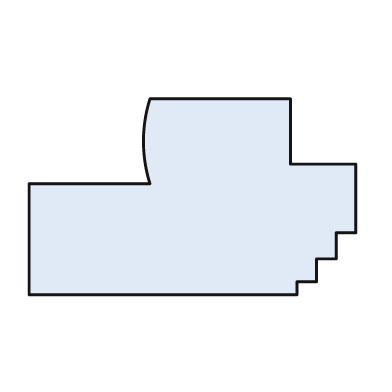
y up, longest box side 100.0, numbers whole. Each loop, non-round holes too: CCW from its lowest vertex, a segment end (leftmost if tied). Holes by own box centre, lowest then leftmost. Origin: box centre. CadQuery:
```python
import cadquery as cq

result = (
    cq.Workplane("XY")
    .moveTo(-50.0, -30.0)
    .lineTo(32.0, -30.0)
    .lineTo(32.0, -26.0)
    .lineTo(38.0, -26.0)
    .lineTo(38.0, -19.0)
    .lineTo(44.0, -19.0)
    .lineTo(44.0, -11.0)
    .lineTo(50.0, -11.0)
    .lineTo(50.0, 10.0)
    .lineTo(30.0, 10.0)
    .lineTo(30.0, 30.0)
    .lineTo(-13.0, 30.0)
    .threePointArc((-15.0, 17.0), (-13.0, 4.0))
    .lineTo(-50.0, 4.0)
    .close()
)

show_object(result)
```